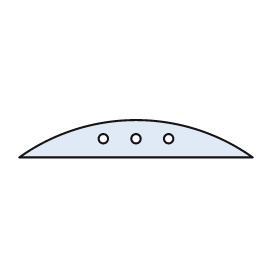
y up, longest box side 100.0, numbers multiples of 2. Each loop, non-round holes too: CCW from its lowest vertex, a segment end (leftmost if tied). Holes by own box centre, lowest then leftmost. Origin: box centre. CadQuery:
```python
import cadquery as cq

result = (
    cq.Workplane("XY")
    .moveTo(-50.0, -8.0)
    .lineTo(50.0, -8.0)
    .threePointArc((0.0, 8.0), (-50.0, -8.0))
    .close()
    .moveTo(-14.0, 0.0)
    .circle(2.0)
    .moveTo(0.0, 0.0)
    .circle(2.0)
    .moveTo(14.0, 0.0)
    .circle(2.0)
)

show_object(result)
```